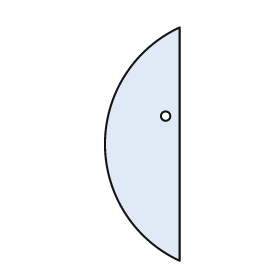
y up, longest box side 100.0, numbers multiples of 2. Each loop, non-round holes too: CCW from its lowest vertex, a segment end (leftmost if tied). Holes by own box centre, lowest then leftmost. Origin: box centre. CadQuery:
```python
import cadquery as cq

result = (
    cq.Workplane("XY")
    .moveTo(16.0, -50.0)
    .lineTo(16.0, 50.0)
    .threePointArc((-16.0, 0.0), (16.0, -50.0))
    .close()
    .moveTo(10.0, 12.0)
    .circle(2.0)
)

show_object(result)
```